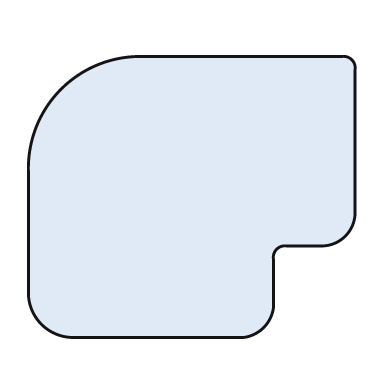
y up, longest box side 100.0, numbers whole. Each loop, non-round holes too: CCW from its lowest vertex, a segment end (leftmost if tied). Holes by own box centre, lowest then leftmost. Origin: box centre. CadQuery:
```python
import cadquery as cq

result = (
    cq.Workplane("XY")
    .moveTo(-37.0, -43.0)
    .lineTo(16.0, -43.0)
    .threePointArc((22.0, -40.0), (25.0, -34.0))
    .lineTo(25.0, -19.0)
    .threePointArc((26.0, -16.0), (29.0, -15.0))
    .lineTo(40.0, -15.0)
    .threePointArc((47.0, -12.0), (50.0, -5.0))
    .lineTo(50.0, 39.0)
    .threePointArc((49.0, 42.0), (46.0, 43.0))
    .lineTo(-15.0, 43.0)
    .threePointArc((-40.0, 33.0), (-50.0, 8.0))
    .lineTo(-50.0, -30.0)
    .threePointArc((-46.0, -39.0), (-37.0, -43.0))
    .close()
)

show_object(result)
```